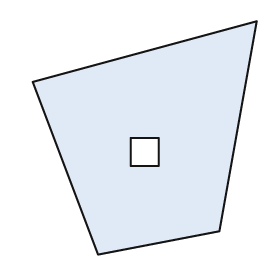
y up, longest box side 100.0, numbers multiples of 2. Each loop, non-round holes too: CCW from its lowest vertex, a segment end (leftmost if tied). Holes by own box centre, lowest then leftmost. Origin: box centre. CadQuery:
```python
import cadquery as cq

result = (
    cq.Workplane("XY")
    .moveTo(-20.0, -50.0)
    .lineTo(32.0, -40.0)
    .lineTo(48.0, 50.0)
    .lineTo(-48.0, 24.0)
    .close()
    .moveTo(-6.0, -12.0)
    .lineTo(6.0, -12.0)
    .lineTo(6.0, 0.0)
    .lineTo(-6.0, 0.0)
    .close()
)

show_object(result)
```